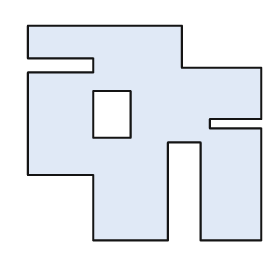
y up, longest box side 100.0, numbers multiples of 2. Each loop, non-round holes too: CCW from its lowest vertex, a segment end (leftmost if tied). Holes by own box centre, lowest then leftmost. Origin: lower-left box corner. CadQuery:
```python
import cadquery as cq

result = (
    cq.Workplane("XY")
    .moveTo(28.0, 0.0)
    .lineTo(60.0, 0.0)
    .lineTo(60.0, 42.0)
    .lineTo(74.0, 42.0)
    .lineTo(74.0, 0.0)
    .lineTo(100.0, 0.0)
    .lineTo(100.0, 48.0)
    .lineTo(78.0, 48.0)
    .lineTo(78.0, 52.0)
    .lineTo(100.0, 52.0)
    .lineTo(100.0, 74.0)
    .lineTo(66.0, 74.0)
    .lineTo(66.0, 92.0)
    .lineTo(0.0, 92.0)
    .lineTo(0.0, 78.0)
    .lineTo(28.0, 78.0)
    .lineTo(28.0, 72.0)
    .lineTo(0.0, 72.0)
    .lineTo(0.0, 28.0)
    .lineTo(28.0, 28.0)
    .close()
    .moveTo(28.0, 44.0)
    .lineTo(44.0, 44.0)
    .lineTo(44.0, 64.0)
    .lineTo(28.0, 64.0)
    .close()
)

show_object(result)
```